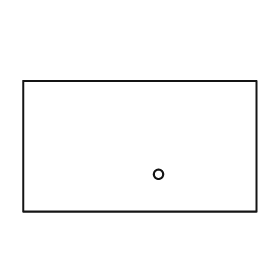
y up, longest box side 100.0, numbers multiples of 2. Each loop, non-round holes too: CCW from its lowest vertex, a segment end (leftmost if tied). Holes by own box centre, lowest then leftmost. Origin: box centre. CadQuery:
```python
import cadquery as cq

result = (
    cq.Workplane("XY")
    .moveTo(-50.0, -28.0)
    .lineTo(50.0, -28.0)
    .lineTo(50.0, 28.0)
    .lineTo(-50.0, 28.0)
    .close()
    .moveTo(8.0, -12.0)
    .circle(2.0)
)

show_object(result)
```